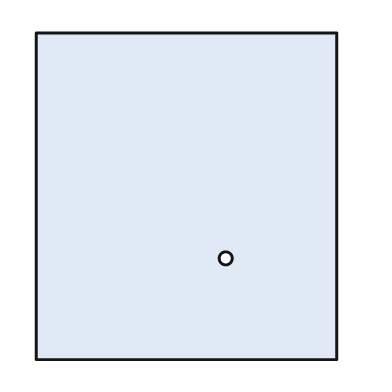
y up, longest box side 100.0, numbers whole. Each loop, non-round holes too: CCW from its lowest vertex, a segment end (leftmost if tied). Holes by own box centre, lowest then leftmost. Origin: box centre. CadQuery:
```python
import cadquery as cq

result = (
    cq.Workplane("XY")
    .moveTo(-46.0, -50.0)
    .lineTo(46.0, -50.0)
    .lineTo(46.0, 50.0)
    .lineTo(-46.0, 50.0)
    .close()
    .moveTo(12.0, -19.0)
    .circle(2.0)
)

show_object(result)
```